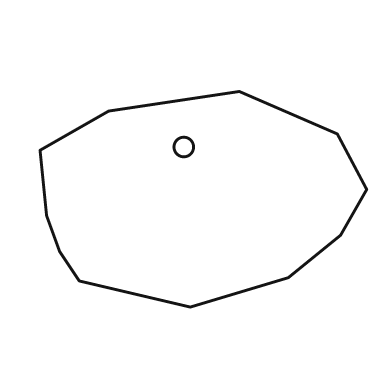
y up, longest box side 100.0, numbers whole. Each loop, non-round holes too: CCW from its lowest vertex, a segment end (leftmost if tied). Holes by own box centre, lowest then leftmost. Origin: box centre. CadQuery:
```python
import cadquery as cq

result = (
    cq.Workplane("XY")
    .moveTo(-4.0, -33.0)
    .lineTo(26.0, -24.0)
    .lineTo(42.0, -11.0)
    .lineTo(50.0, 3.0)
    .lineTo(41.0, 20.0)
    .lineTo(11.0, 33.0)
    .lineTo(-29.0, 27.0)
    .lineTo(-50.0, 15.0)
    .lineTo(-48.0, -5.0)
    .lineTo(-44.0, -16.0)
    .lineTo(-38.0, -25.0)
    .close()
    .moveTo(-6.0, 16.0)
    .circle(3.0)
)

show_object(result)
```